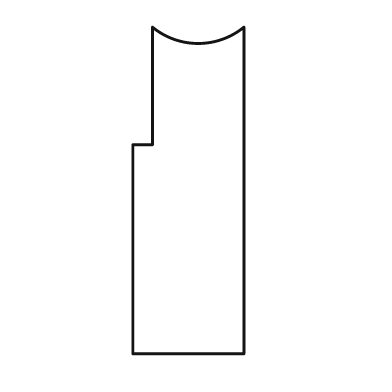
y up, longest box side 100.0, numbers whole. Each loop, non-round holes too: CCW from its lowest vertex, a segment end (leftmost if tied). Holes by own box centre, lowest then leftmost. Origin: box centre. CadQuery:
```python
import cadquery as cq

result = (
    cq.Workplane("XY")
    .moveTo(-17.0, -50.0)
    .lineTo(17.0, -50.0)
    .lineTo(17.0, 50.0)
    .threePointArc((3.0, 45.0), (-11.0, 50.0))
    .lineTo(-11.0, 14.0)
    .lineTo(-17.0, 14.0)
    .close()
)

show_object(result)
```